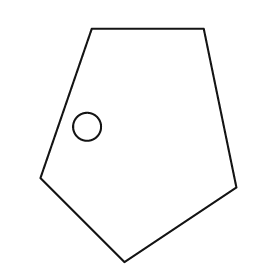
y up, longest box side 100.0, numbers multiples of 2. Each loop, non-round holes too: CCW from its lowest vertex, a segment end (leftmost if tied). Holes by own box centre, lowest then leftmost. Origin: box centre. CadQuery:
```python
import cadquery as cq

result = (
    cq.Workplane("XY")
    .moveTo(-6.0, -50.0)
    .lineTo(42.0, -18.0)
    .lineTo(28.0, 50.0)
    .lineTo(-20.0, 50.0)
    .lineTo(-42.0, -14.0)
    .close()
    .moveTo(-22.0, 8.0)
    .circle(6.0)
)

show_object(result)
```